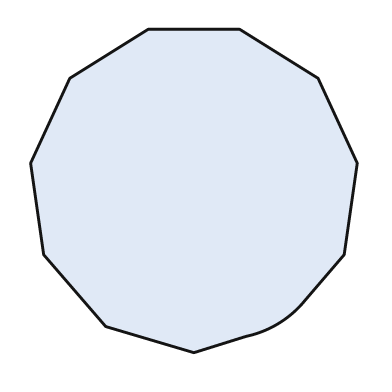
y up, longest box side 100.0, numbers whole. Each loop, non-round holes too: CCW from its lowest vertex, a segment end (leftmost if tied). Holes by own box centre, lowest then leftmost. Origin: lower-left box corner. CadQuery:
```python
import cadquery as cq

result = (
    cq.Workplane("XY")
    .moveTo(50.0, 0.0)
    .lineTo(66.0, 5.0)
    .threePointArc((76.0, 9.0), (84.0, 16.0))
    .lineTo(96.0, 30.0)
    .lineTo(100.0, 58.0)
    .lineTo(88.0, 84.0)
    .lineTo(64.0, 99.0)
    .lineTo(36.0, 99.0)
    .lineTo(12.0, 84.0)
    .lineTo(0.0, 58.0)
    .lineTo(4.0, 30.0)
    .lineTo(23.0, 8.0)
    .close()
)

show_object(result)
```